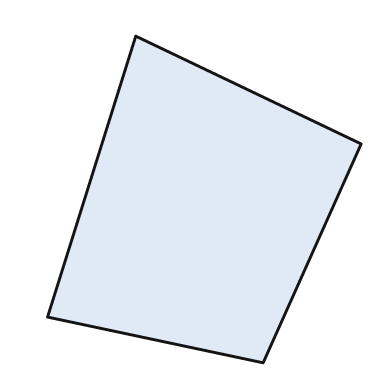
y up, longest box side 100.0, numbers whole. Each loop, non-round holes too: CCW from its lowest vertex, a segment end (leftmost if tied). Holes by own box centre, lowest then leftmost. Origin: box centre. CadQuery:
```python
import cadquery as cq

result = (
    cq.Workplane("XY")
    .moveTo(18.0, -50.0)
    .lineTo(48.0, 17.0)
    .lineTo(-21.0, 50.0)
    .lineTo(-48.0, -36.0)
    .close()
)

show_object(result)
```